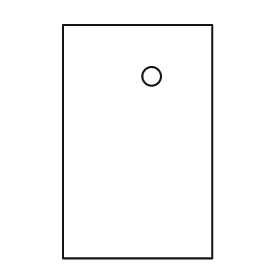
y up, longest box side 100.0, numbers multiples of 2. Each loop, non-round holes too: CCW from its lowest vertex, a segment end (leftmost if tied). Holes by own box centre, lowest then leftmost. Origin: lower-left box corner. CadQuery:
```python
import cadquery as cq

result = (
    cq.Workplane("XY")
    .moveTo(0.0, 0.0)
    .lineTo(64.0, 0.0)
    .lineTo(64.0, 100.0)
    .lineTo(0.0, 100.0)
    .close()
    .moveTo(38.0, 78.0)
    .circle(4.0)
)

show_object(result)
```